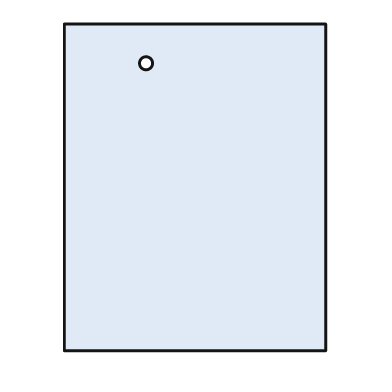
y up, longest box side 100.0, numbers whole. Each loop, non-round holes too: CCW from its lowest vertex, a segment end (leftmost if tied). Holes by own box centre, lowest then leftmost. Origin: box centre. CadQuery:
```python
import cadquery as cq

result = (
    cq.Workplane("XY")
    .moveTo(-40.0, -50.0)
    .lineTo(40.0, -50.0)
    .lineTo(40.0, 50.0)
    .lineTo(-40.0, 50.0)
    .close()
    .moveTo(-15.0, 38.0)
    .circle(2.0)
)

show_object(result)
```